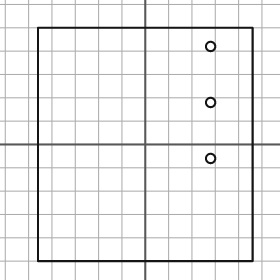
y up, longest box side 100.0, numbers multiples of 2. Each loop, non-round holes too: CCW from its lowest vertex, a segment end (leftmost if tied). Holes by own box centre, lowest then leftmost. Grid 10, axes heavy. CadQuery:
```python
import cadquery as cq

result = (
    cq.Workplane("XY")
    .moveTo(-46.0, -50.0)
    .lineTo(46.0, -50.0)
    .lineTo(46.0, 50.0)
    .lineTo(-46.0, 50.0)
    .close()
    .moveTo(28.0, -6.0)
    .circle(2.0)
    .moveTo(28.0, 18.0)
    .circle(2.0)
    .moveTo(28.0, 42.0)
    .circle(2.0)
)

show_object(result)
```